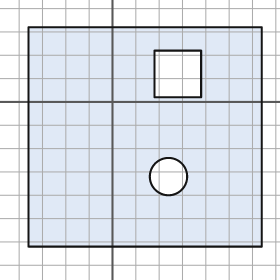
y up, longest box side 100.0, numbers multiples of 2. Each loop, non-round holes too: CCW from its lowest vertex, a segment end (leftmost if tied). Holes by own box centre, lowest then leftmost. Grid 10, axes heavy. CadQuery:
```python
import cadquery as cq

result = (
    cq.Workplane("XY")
    .moveTo(-36.0, -62.0)
    .lineTo(64.0, -62.0)
    .lineTo(64.0, 32.0)
    .lineTo(-36.0, 32.0)
    .close()
    .moveTo(24.0, -32.0)
    .circle(8.0)
    .moveTo(18.0, 2.0)
    .lineTo(38.0, 2.0)
    .lineTo(38.0, 22.0)
    .lineTo(18.0, 22.0)
    .close()
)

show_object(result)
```